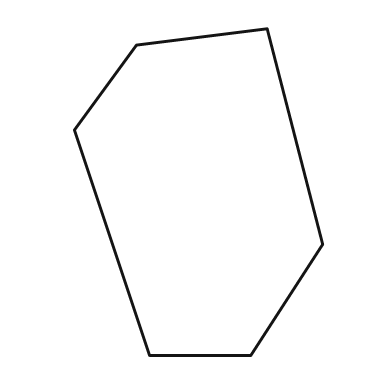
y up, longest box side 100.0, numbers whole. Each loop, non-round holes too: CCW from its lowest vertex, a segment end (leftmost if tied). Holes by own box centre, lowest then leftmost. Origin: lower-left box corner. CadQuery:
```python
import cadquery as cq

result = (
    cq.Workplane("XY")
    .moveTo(23.0, 0.0)
    .lineTo(54.0, 0.0)
    .lineTo(76.0, 34.0)
    .lineTo(59.0, 100.0)
    .lineTo(19.0, 95.0)
    .lineTo(0.0, 69.0)
    .close()
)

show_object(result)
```